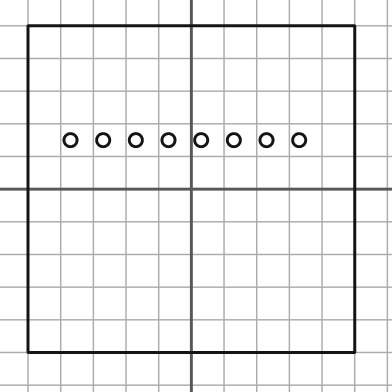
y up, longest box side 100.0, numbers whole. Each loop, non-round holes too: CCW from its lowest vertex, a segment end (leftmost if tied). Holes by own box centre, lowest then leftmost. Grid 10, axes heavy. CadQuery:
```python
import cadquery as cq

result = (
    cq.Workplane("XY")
    .moveTo(-50.0, -50.0)
    .lineTo(50.0, -50.0)
    .lineTo(50.0, 50.0)
    .lineTo(-50.0, 50.0)
    .close()
    .moveTo(-37.0, 15.0)
    .circle(2.0)
    .moveTo(-27.0, 15.0)
    .circle(2.0)
    .moveTo(-17.0, 15.0)
    .circle(2.0)
    .moveTo(-7.0, 15.0)
    .circle(2.0)
    .moveTo(3.0, 15.0)
    .circle(2.0)
    .moveTo(13.0, 15.0)
    .circle(2.0)
    .moveTo(23.0, 15.0)
    .circle(2.0)
    .moveTo(33.0, 15.0)
    .circle(2.0)
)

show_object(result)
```